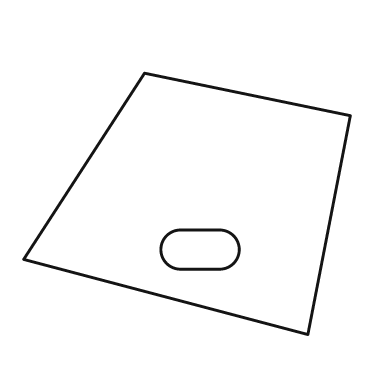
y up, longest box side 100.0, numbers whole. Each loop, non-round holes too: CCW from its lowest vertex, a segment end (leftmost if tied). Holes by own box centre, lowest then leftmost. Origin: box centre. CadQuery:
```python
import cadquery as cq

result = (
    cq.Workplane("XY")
    .moveTo(37.0, -40.0)
    .lineTo(50.0, 27.0)
    .lineTo(-13.0, 40.0)
    .lineTo(-50.0, -17.0)
    .close()
    .moveTo(-2.0, -20.0)
    .lineTo(10.0, -20.0)
    .threePointArc((16.0, -14.0), (10.0, -8.0))
    .lineTo(-2.0, -8.0)
    .threePointArc((-8.0, -14.0), (-2.0, -20.0))
    .close()
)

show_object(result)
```